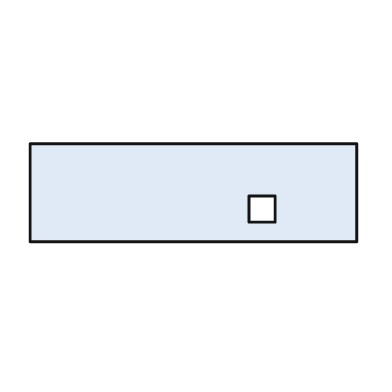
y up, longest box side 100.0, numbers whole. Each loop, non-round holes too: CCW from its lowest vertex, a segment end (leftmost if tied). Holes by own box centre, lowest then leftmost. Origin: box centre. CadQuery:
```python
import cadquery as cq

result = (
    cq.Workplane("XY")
    .moveTo(-50.0, -15.0)
    .lineTo(50.0, -15.0)
    .lineTo(50.0, 15.0)
    .lineTo(-50.0, 15.0)
    .close()
    .moveTo(17.0, -9.0)
    .lineTo(25.0, -9.0)
    .lineTo(25.0, -1.0)
    .lineTo(17.0, -1.0)
    .close()
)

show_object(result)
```